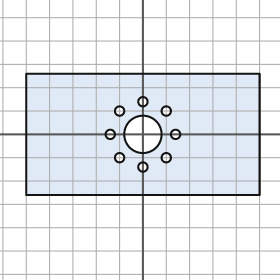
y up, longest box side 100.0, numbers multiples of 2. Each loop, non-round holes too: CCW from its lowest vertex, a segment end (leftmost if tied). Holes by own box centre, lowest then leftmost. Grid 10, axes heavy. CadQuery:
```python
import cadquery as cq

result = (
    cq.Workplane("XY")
    .moveTo(-50.0, -26.0)
    .lineTo(50.0, -26.0)
    .lineTo(50.0, 26.0)
    .lineTo(-50.0, 26.0)
    .close()
    .moveTo(0.0, -14.0)
    .circle(2.0)
    .moveTo(-10.0, -10.0)
    .circle(2.0)
    .moveTo(10.0, -10.0)
    .circle(2.0)
    .moveTo(-14.0, 0.0)
    .circle(2.0)
    .moveTo(0.0, 0.0)
    .circle(8.0)
    .moveTo(14.0, 0.0)
    .circle(2.0)
    .moveTo(-10.0, 10.0)
    .circle(2.0)
    .moveTo(10.0, 10.0)
    .circle(2.0)
    .moveTo(0.0, 14.0)
    .circle(2.0)
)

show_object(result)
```